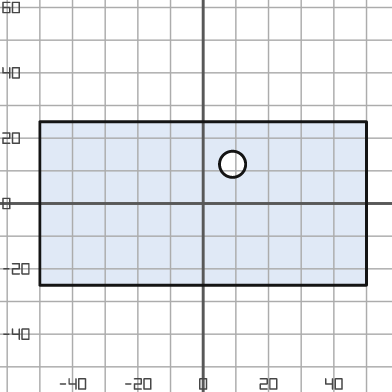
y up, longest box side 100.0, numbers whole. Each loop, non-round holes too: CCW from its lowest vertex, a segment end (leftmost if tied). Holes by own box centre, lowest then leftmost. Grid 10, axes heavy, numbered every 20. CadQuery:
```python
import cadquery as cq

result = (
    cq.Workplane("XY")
    .moveTo(-50.0, -25.0)
    .lineTo(50.0, -25.0)
    .lineTo(50.0, 25.0)
    .lineTo(-50.0, 25.0)
    .close()
    .moveTo(9.0, 12.0)
    .circle(4.0)
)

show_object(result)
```